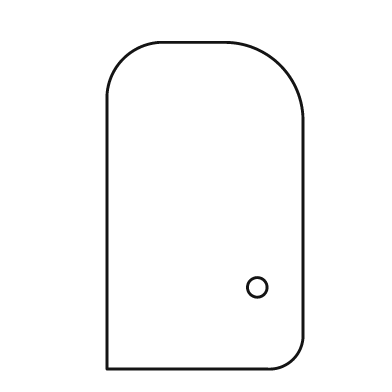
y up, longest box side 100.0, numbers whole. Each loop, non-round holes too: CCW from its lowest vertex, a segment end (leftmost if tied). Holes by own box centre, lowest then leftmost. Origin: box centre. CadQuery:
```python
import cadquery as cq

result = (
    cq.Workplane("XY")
    .moveTo(-30.0, -50.0)
    .lineTo(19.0, -50.0)
    .threePointArc((27.0, -47.0), (30.0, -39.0))
    .lineTo(30.0, 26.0)
    .threePointArc((23.0, 43.0), (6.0, 50.0))
    .lineTo(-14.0, 50.0)
    .threePointArc((-25.0, 45.0), (-30.0, 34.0))
    .close()
    .moveTo(16.0, -25.0)
    .circle(3.0)
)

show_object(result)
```